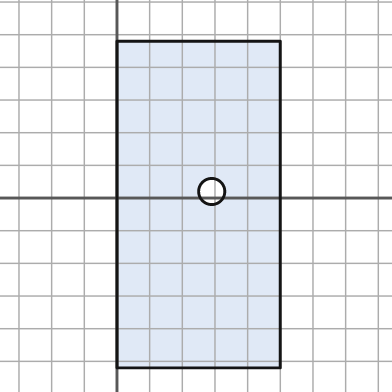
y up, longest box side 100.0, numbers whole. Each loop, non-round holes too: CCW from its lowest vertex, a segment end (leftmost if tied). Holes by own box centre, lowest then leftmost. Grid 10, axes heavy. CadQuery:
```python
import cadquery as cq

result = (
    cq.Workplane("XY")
    .moveTo(0.0, -52.0)
    .lineTo(50.0, -52.0)
    .lineTo(50.0, 48.0)
    .lineTo(0.0, 48.0)
    .close()
    .moveTo(29.0, 2.0)
    .circle(4.0)
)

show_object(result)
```